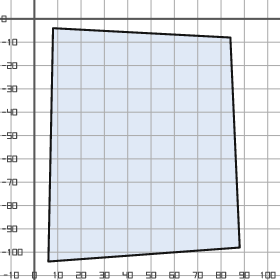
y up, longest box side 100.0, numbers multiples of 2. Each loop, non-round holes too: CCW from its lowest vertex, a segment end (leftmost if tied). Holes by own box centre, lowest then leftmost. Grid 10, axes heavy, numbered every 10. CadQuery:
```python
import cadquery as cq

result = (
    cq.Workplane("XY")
    .moveTo(6.0, -104.0)
    .lineTo(88.0, -98.0)
    .lineTo(84.0, -8.0)
    .lineTo(8.0, -4.0)
    .close()
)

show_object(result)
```